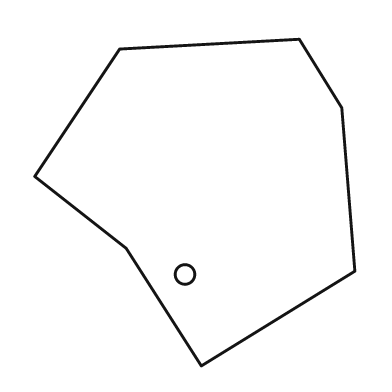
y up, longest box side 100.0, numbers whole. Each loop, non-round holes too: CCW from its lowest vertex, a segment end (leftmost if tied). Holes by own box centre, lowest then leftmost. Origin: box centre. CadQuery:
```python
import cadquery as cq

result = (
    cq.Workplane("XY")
    .moveTo(2.0, -50.0)
    .lineTo(49.0, -21.0)
    .lineTo(45.0, 29.0)
    .lineTo(32.0, 50.0)
    .lineTo(-23.0, 47.0)
    .lineTo(-49.0, 8.0)
    .lineTo(-21.0, -14.0)
    .close()
    .moveTo(-3.0, -22.0)
    .circle(3.0)
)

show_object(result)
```